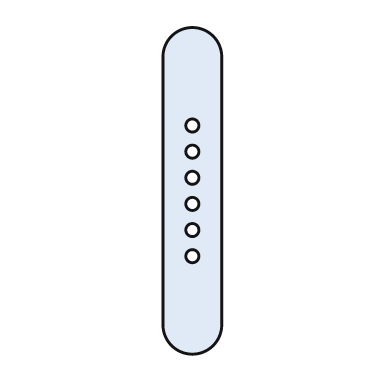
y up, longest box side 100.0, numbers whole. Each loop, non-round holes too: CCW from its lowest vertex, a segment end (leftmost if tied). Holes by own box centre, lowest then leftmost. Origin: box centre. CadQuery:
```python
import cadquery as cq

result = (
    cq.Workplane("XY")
    .moveTo(-9.0, -41.0)
    .threePointArc((0.0, -50.0), (9.0, -41.0))
    .lineTo(9.0, 41.0)
    .threePointArc((0.0, 50.0), (-9.0, 41.0))
    .close()
    .moveTo(0.0, -20.0)
    .circle(2.0)
    .moveTo(0.0, -12.0)
    .circle(2.0)
    .moveTo(0.0, -4.0)
    .circle(2.0)
    .moveTo(0.0, 4.0)
    .circle(2.0)
    .moveTo(0.0, 12.0)
    .circle(2.0)
    .moveTo(0.0, 20.0)
    .circle(2.0)
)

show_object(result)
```